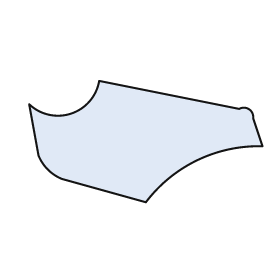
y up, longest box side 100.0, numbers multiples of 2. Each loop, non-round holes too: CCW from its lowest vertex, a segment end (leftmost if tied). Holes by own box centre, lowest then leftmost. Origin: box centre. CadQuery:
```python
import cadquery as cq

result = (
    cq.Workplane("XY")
    .moveTo(0.0, -26.0)
    .threePointArc((22.0, -8.0), (50.0, -2.0))
    .lineTo(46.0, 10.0)
    .threePointArc((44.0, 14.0), (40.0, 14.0))
    .lineTo(-20.0, 26.0)
    .threePointArc((-32.0, 12.0), (-50.0, 16.0))
    .lineTo(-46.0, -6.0)
    .threePointArc((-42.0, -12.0), (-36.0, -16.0))
    .close()
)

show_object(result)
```